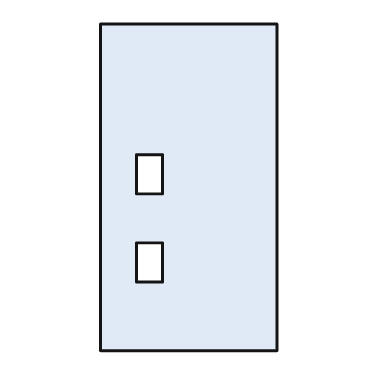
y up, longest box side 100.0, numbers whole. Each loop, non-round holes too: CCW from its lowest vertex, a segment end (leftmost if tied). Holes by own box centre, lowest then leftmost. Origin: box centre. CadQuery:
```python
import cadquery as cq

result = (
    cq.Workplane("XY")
    .moveTo(-27.0, -50.0)
    .lineTo(27.0, -50.0)
    .lineTo(27.0, 50.0)
    .lineTo(-27.0, 50.0)
    .close()
    .moveTo(-16.0, -29.0)
    .lineTo(-8.0, -29.0)
    .lineTo(-8.0, -17.0)
    .lineTo(-16.0, -17.0)
    .close()
    .moveTo(-16.0, -2.0)
    .lineTo(-8.0, -2.0)
    .lineTo(-8.0, 10.0)
    .lineTo(-16.0, 10.0)
    .close()
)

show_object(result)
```